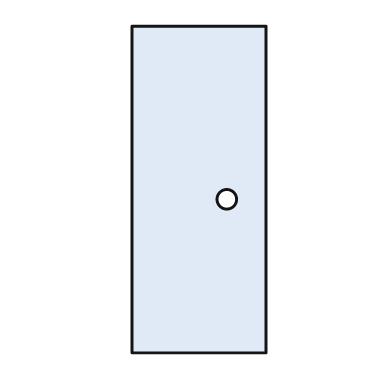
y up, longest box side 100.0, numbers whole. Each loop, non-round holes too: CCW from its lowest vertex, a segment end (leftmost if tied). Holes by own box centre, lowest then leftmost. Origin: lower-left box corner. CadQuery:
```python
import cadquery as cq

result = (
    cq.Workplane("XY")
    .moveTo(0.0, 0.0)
    .lineTo(41.0, 0.0)
    .lineTo(41.0, 100.0)
    .lineTo(0.0, 100.0)
    .close()
    .moveTo(29.0, 47.0)
    .circle(3.0)
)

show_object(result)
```